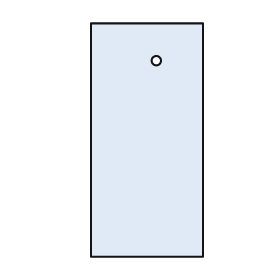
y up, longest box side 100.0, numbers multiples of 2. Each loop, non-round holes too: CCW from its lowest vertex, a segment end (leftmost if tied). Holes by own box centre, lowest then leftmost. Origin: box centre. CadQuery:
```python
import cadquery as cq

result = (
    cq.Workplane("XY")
    .moveTo(-24.0, -50.0)
    .lineTo(24.0, -50.0)
    .lineTo(24.0, 50.0)
    .lineTo(-24.0, 50.0)
    .close()
    .moveTo(4.0, 34.0)
    .circle(2.0)
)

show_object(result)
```